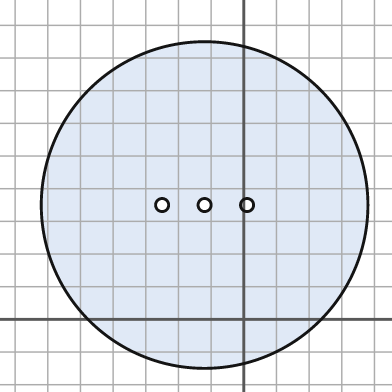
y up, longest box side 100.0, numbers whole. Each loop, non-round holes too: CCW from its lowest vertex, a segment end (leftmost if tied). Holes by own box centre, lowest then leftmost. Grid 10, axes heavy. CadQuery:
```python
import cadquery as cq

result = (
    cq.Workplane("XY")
    .moveTo(-12.0, 35.0)
    .circle(50.0)
    .moveTo(-25.0, 35.0)
    .circle(2.0)
    .moveTo(-12.0, 35.0)
    .circle(2.0)
    .moveTo(1.0, 35.0)
    .circle(2.0)
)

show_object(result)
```